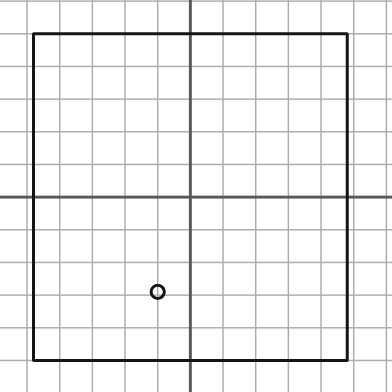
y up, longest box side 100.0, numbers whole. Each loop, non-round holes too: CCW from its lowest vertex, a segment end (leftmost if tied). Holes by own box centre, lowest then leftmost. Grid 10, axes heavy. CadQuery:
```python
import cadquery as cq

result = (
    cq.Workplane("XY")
    .moveTo(-48.0, -50.0)
    .lineTo(48.0, -50.0)
    .lineTo(48.0, 50.0)
    .lineTo(-48.0, 50.0)
    .close()
    .moveTo(-10.0, -29.0)
    .circle(2.0)
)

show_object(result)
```